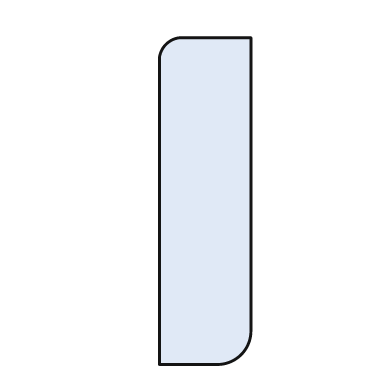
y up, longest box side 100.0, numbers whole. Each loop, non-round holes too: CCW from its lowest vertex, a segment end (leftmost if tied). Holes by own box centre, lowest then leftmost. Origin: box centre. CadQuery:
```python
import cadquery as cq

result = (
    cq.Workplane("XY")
    .moveTo(-14.0, -50.0)
    .lineTo(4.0, -50.0)
    .threePointArc((11.0, -47.0), (14.0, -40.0))
    .lineTo(14.0, 50.0)
    .lineTo(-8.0, 50.0)
    .threePointArc((-12.0, 48.0), (-14.0, 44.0))
    .close()
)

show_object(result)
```